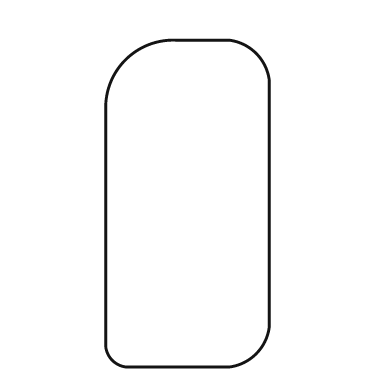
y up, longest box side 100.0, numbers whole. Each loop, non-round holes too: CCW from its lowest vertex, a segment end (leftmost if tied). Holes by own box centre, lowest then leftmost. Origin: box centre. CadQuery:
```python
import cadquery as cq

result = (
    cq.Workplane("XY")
    .moveTo(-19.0, -50.0)
    .lineTo(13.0, -50.0)
    .threePointArc((21.0, -46.0), (25.0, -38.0))
    .lineTo(25.0, 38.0)
    .threePointArc((21.0, 46.0), (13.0, 50.0))
    .lineTo(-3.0, 50.0)
    .threePointArc((-19.0, 44.0), (-25.0, 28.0))
    .lineTo(-25.0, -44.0)
    .threePointArc((-23.0, -48.0), (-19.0, -50.0))
    .close()
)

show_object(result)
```